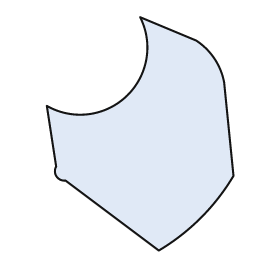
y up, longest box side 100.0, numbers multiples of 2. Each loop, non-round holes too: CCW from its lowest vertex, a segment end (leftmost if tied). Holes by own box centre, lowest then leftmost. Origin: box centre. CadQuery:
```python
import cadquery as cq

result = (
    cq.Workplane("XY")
    .moveTo(8.0, -50.0)
    .threePointArc((26.0, -36.0), (40.0, -18.0))
    .lineTo(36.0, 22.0)
    .threePointArc((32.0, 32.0), (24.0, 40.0))
    .lineTo(0.0, 50.0)
    .threePointArc((-6.0, 16.0), (-40.0, 12.0))
    .lineTo(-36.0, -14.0)
    .threePointArc((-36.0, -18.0), (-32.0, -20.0))
    .close()
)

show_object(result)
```